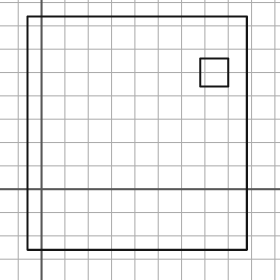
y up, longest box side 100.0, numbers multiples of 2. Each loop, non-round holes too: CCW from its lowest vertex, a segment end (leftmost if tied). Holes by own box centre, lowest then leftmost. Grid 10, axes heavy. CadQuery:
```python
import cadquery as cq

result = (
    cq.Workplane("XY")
    .moveTo(-6.0, -26.0)
    .lineTo(88.0, -26.0)
    .lineTo(88.0, 74.0)
    .lineTo(-6.0, 74.0)
    .close()
    .moveTo(68.0, 44.0)
    .lineTo(80.0, 44.0)
    .lineTo(80.0, 56.0)
    .lineTo(68.0, 56.0)
    .close()
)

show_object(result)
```